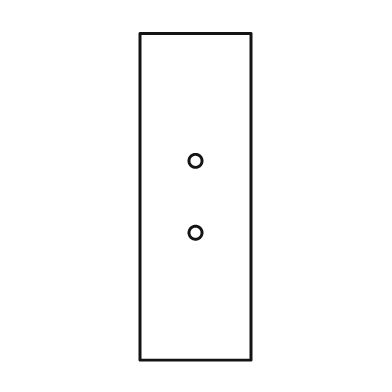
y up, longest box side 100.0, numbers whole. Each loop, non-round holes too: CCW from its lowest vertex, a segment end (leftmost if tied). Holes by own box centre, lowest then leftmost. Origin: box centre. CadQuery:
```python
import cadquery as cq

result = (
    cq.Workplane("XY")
    .moveTo(-17.0, -50.0)
    .lineTo(17.0, -50.0)
    .lineTo(17.0, 50.0)
    .lineTo(-17.0, 50.0)
    .close()
    .moveTo(0.0, -11.0)
    .circle(2.0)
    .moveTo(0.0, 11.0)
    .circle(2.0)
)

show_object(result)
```